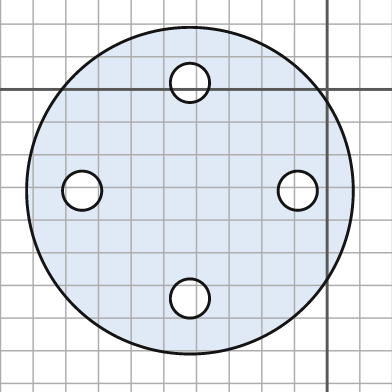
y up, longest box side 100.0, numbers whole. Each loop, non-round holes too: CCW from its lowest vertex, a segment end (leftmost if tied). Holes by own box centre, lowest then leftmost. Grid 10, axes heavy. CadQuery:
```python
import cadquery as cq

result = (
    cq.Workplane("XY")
    .moveTo(-42.0, -31.0)
    .circle(50.0)
    .moveTo(-42.0, -64.0)
    .circle(6.0)
    .moveTo(-75.0, -31.0)
    .circle(6.0)
    .moveTo(-9.0, -31.0)
    .circle(6.0)
    .moveTo(-42.0, 2.0)
    .circle(6.0)
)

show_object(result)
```